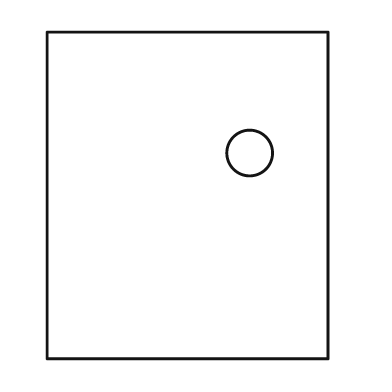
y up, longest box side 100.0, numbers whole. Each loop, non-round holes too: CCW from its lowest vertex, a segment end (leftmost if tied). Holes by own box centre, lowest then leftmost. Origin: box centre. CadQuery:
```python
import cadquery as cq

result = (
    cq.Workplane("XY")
    .moveTo(-43.0, -50.0)
    .lineTo(43.0, -50.0)
    .lineTo(43.0, 50.0)
    .lineTo(-43.0, 50.0)
    .close()
    .moveTo(19.0, 13.0)
    .circle(7.0)
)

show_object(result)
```